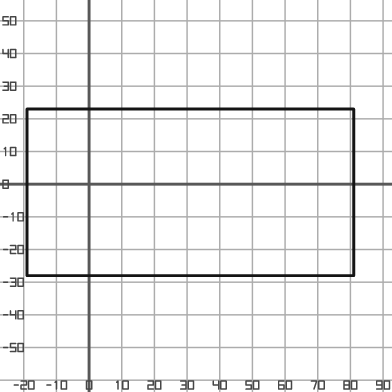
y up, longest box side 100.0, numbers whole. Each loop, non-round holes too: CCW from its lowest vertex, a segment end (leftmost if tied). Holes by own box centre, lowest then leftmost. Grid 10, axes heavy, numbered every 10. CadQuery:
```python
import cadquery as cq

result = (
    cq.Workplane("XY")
    .moveTo(-19.0, -28.0)
    .lineTo(81.0, -28.0)
    .lineTo(81.0, 23.0)
    .lineTo(-19.0, 23.0)
    .close()
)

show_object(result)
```